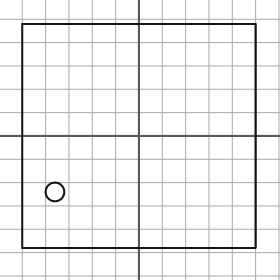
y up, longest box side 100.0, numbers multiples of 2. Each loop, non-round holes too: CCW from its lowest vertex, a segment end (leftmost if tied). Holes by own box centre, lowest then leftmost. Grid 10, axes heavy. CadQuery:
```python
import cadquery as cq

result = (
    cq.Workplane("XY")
    .moveTo(-50.0, -48.0)
    .lineTo(50.0, -48.0)
    .lineTo(50.0, 48.0)
    .lineTo(-50.0, 48.0)
    .close()
    .moveTo(-36.0, -24.0)
    .circle(4.0)
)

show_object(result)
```